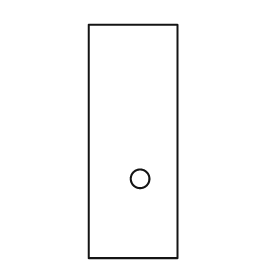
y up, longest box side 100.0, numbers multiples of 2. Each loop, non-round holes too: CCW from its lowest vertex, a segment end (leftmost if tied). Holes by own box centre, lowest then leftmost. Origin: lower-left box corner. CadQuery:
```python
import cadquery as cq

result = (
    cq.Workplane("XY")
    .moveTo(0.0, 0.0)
    .lineTo(38.0, 0.0)
    .lineTo(38.0, 100.0)
    .lineTo(0.0, 100.0)
    .close()
    .moveTo(22.0, 34.0)
    .circle(4.0)
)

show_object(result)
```